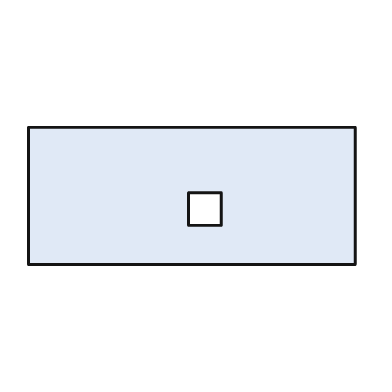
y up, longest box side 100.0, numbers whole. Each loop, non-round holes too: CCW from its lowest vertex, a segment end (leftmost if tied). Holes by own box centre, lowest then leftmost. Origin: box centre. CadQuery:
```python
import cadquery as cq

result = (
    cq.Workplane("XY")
    .moveTo(-50.0, -21.0)
    .lineTo(50.0, -21.0)
    .lineTo(50.0, 21.0)
    .lineTo(-50.0, 21.0)
    .close()
    .moveTo(-1.0, -9.0)
    .lineTo(9.0, -9.0)
    .lineTo(9.0, 1.0)
    .lineTo(-1.0, 1.0)
    .close()
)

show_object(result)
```